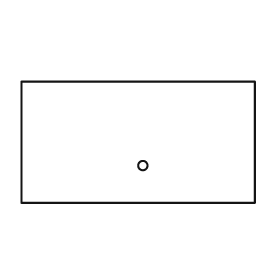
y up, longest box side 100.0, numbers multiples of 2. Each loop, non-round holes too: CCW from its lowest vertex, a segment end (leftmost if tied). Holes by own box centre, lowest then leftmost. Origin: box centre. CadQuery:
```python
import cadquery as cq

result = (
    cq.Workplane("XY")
    .moveTo(-50.0, -26.0)
    .lineTo(50.0, -26.0)
    .lineTo(50.0, 26.0)
    .lineTo(-50.0, 26.0)
    .close()
    .moveTo(2.0, -10.0)
    .circle(2.0)
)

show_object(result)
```